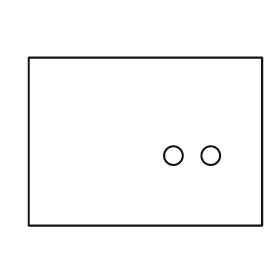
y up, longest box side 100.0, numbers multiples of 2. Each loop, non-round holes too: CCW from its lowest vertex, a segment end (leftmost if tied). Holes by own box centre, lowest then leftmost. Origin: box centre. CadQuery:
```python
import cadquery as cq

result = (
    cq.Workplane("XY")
    .moveTo(-50.0, -36.0)
    .lineTo(50.0, -36.0)
    .lineTo(50.0, 36.0)
    .lineTo(-50.0, 36.0)
    .close()
    .moveTo(12.0, -6.0)
    .circle(4.0)
    .moveTo(28.0, -6.0)
    .circle(4.0)
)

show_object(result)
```